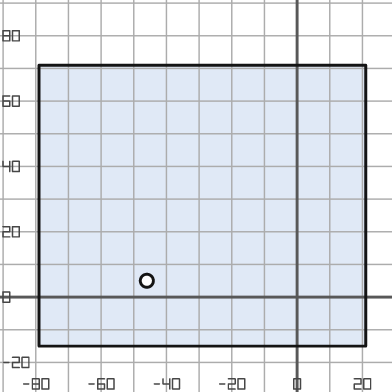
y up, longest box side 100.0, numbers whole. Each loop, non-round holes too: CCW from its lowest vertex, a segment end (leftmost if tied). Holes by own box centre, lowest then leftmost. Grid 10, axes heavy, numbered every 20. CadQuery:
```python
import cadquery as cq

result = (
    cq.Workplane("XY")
    .moveTo(-79.0, -15.0)
    .lineTo(21.0, -15.0)
    .lineTo(21.0, 71.0)
    .lineTo(-79.0, 71.0)
    .close()
    .moveTo(-46.0, 5.0)
    .circle(2.0)
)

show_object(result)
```